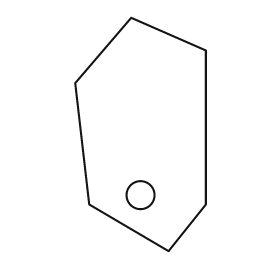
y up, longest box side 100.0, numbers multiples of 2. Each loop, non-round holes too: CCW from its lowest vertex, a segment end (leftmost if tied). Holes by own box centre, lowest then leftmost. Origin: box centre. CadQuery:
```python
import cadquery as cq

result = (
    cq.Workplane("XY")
    .moveTo(12.0, -50.0)
    .lineTo(28.0, -30.0)
    .lineTo(28.0, 36.0)
    .lineTo(-4.0, 50.0)
    .lineTo(-28.0, 22.0)
    .lineTo(-22.0, -30.0)
    .close()
    .moveTo(0.0, -26.0)
    .circle(6.0)
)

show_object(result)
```